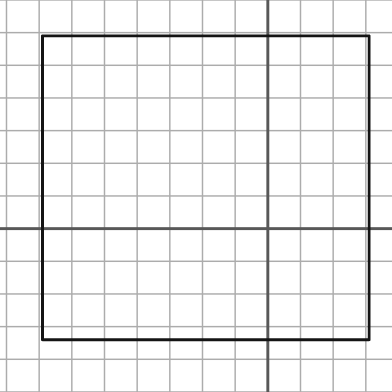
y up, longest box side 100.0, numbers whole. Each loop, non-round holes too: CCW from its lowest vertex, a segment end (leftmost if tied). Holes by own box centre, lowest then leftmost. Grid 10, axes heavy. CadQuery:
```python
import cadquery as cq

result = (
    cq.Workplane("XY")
    .moveTo(-69.0, -34.0)
    .lineTo(31.0, -34.0)
    .lineTo(31.0, 59.0)
    .lineTo(-69.0, 59.0)
    .close()
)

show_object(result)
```